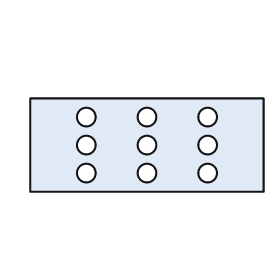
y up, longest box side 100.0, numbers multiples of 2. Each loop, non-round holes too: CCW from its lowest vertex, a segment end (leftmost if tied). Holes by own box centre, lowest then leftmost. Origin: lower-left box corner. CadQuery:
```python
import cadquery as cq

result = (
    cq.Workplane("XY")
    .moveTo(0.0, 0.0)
    .lineTo(100.0, 0.0)
    .lineTo(100.0, 40.0)
    .lineTo(0.0, 40.0)
    .close()
    .moveTo(24.0, 8.0)
    .circle(4.0)
    .moveTo(50.0, 8.0)
    .circle(4.0)
    .moveTo(76.0, 8.0)
    .circle(4.0)
    .moveTo(24.0, 20.0)
    .circle(4.0)
    .moveTo(50.0, 20.0)
    .circle(4.0)
    .moveTo(76.0, 20.0)
    .circle(4.0)
    .moveTo(24.0, 32.0)
    .circle(4.0)
    .moveTo(50.0, 32.0)
    .circle(4.0)
    .moveTo(76.0, 32.0)
    .circle(4.0)
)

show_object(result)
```